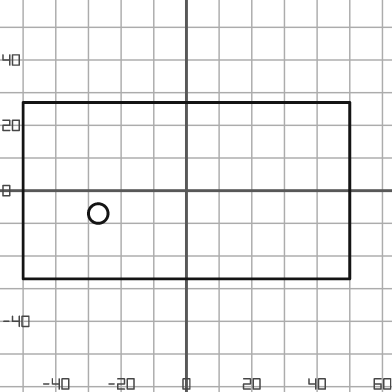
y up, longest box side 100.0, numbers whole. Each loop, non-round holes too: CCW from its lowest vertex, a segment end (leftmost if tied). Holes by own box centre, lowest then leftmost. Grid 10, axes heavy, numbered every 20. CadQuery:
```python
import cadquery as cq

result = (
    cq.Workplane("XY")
    .moveTo(-50.0, -27.0)
    .lineTo(50.0, -27.0)
    .lineTo(50.0, 27.0)
    .lineTo(-50.0, 27.0)
    .close()
    .moveTo(-27.0, -7.0)
    .circle(3.0)
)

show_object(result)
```